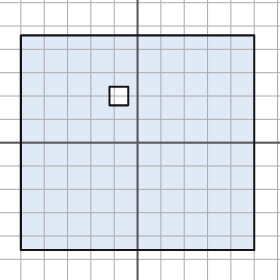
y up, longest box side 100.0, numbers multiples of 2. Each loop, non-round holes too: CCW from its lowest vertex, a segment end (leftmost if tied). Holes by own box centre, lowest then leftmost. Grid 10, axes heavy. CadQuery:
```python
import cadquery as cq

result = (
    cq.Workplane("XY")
    .moveTo(-50.0, -46.0)
    .lineTo(50.0, -46.0)
    .lineTo(50.0, 46.0)
    .lineTo(-50.0, 46.0)
    .close()
    .moveTo(-12.0, 16.0)
    .lineTo(-4.0, 16.0)
    .lineTo(-4.0, 24.0)
    .lineTo(-12.0, 24.0)
    .close()
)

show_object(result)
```